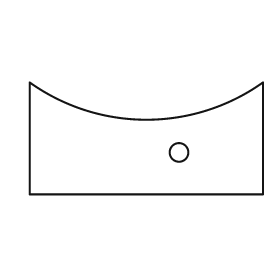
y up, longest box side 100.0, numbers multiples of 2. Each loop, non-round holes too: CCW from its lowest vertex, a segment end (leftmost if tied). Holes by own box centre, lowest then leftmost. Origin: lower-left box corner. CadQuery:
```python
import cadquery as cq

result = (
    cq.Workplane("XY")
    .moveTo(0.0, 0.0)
    .lineTo(100.0, 0.0)
    .lineTo(100.0, 48.0)
    .threePointArc((50.0, 32.0), (0.0, 48.0))
    .close()
    .moveTo(64.0, 18.0)
    .circle(4.0)
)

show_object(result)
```